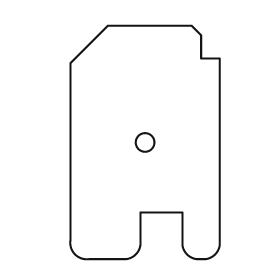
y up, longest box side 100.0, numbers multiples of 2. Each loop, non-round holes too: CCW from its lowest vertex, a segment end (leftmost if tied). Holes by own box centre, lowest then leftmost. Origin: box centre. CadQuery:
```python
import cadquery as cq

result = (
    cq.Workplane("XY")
    .moveTo(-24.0, -50.0)
    .lineTo(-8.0, -50.0)
    .threePointArc((-4.0, -48.0), (-2.0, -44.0))
    .lineTo(-2.0, -30.0)
    .lineTo(16.0, -30.0)
    .lineTo(16.0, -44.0)
    .threePointArc((18.0, -48.0), (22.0, -50.0))
    .lineTo(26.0, -50.0)
    .threePointArc((30.0, -48.0), (32.0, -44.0))
    .lineTo(32.0, 36.0)
    .lineTo(24.0, 36.0)
    .lineTo(24.0, 46.0)
    .lineTo(20.0, 50.0)
    .lineTo(-16.0, 50.0)
    .lineTo(-32.0, 34.0)
    .lineTo(-32.0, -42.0)
    .threePointArc((-30.0, -48.0), (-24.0, -50.0))
    .close()
    .moveTo(0.0, 0.0)
    .circle(4.0)
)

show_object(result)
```